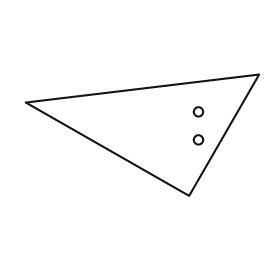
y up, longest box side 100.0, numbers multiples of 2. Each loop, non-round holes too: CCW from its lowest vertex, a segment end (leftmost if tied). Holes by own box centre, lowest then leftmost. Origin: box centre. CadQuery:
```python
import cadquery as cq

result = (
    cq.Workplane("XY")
    .moveTo(20.0, -26.0)
    .lineTo(50.0, 26.0)
    .lineTo(-50.0, 14.0)
    .close()
    .moveTo(24.0, -2.0)
    .circle(2.0)
    .moveTo(24.0, 10.0)
    .circle(2.0)
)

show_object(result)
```